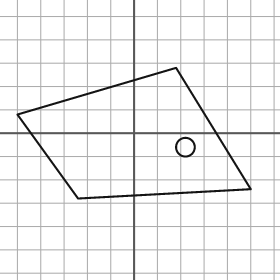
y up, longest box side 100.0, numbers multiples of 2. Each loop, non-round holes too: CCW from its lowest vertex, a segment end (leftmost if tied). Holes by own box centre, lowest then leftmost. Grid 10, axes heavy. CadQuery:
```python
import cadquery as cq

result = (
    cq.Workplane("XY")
    .moveTo(-24.0, -28.0)
    .lineTo(50.0, -24.0)
    .lineTo(18.0, 28.0)
    .lineTo(-50.0, 8.0)
    .close()
    .moveTo(22.0, -6.0)
    .circle(4.0)
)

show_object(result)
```